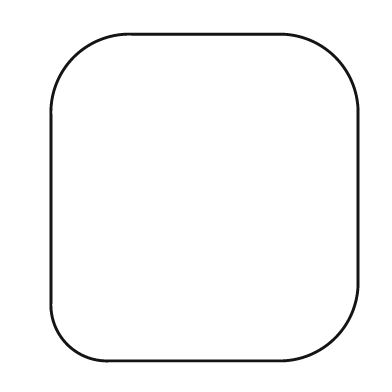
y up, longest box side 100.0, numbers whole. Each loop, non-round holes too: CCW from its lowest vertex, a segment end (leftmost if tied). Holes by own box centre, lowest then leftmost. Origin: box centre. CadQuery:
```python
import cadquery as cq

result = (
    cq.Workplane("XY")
    .moveTo(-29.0, -50.0)
    .lineTo(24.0, -50.0)
    .threePointArc((40.0, -43.0), (47.0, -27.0))
    .lineTo(47.0, 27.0)
    .threePointArc((40.0, 43.0), (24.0, 50.0))
    .lineTo(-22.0, 50.0)
    .threePointArc((-40.0, 43.0), (-47.0, 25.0))
    .lineTo(-47.0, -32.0)
    .threePointArc((-42.0, -45.0), (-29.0, -50.0))
    .close()
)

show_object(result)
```